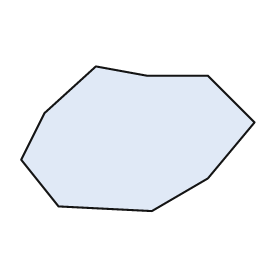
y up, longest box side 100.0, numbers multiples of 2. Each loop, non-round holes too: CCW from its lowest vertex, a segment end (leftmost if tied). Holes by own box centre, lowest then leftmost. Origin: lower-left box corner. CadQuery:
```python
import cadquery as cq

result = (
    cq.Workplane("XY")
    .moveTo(56.0, 0.0)
    .lineTo(80.0, 14.0)
    .lineTo(100.0, 38.0)
    .lineTo(80.0, 58.0)
    .lineTo(54.0, 58.0)
    .lineTo(32.0, 62.0)
    .lineTo(10.0, 42.0)
    .lineTo(0.0, 22.0)
    .lineTo(16.0, 2.0)
    .close()
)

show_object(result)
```